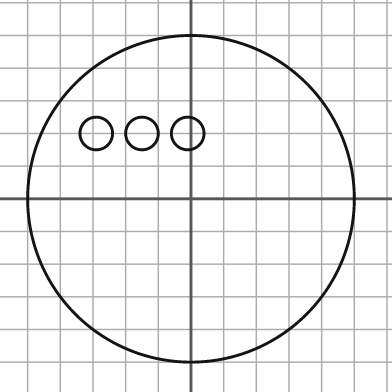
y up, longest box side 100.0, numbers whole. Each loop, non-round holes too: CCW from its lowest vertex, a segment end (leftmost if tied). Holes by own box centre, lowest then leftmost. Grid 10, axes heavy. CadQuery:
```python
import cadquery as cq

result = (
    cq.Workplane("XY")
    .moveTo(0.0, 0.0)
    .circle(50.0)
    .moveTo(-29.0, 20.0)
    .circle(5.0)
    .moveTo(-15.0, 20.0)
    .circle(5.0)
    .moveTo(-1.0, 20.0)
    .circle(5.0)
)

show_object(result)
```